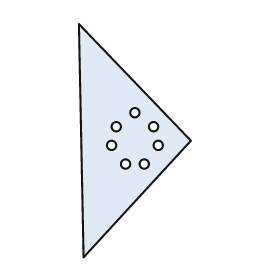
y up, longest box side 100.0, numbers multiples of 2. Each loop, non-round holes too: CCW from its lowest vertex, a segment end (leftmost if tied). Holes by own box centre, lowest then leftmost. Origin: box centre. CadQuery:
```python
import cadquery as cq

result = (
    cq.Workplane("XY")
    .moveTo(-22.0, -50.0)
    .lineTo(24.0, 0.0)
    .lineTo(-24.0, 50.0)
    .close()
    .moveTo(-4.0, -10.0)
    .circle(2.0)
    .moveTo(4.0, -10.0)
    .circle(2.0)
    .moveTo(-10.0, -2.0)
    .circle(2.0)
    .moveTo(10.0, -2.0)
    .circle(2.0)
    .moveTo(-8.0, 6.0)
    .circle(2.0)
    .moveTo(8.0, 6.0)
    .circle(2.0)
    .moveTo(0.0, 12.0)
    .circle(2.0)
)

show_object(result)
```